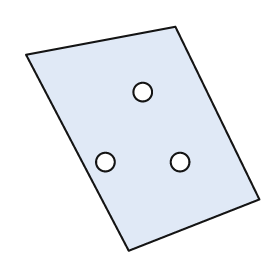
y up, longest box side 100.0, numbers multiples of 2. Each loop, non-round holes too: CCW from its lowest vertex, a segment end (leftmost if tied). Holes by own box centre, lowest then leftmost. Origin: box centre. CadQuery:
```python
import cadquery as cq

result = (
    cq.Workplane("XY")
    .moveTo(-6.0, -48.0)
    .lineTo(50.0, -26.0)
    .lineTo(14.0, 48.0)
    .lineTo(-50.0, 36.0)
    .close()
    .moveTo(-16.0, -10.0)
    .circle(4.0)
    .moveTo(16.0, -10.0)
    .circle(4.0)
    .moveTo(0.0, 20.0)
    .circle(4.0)
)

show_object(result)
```